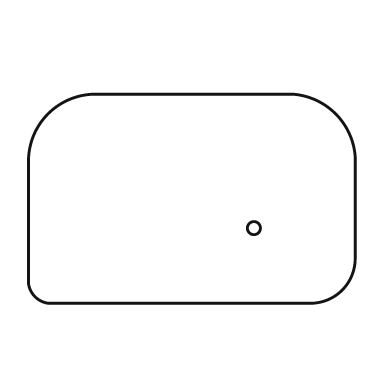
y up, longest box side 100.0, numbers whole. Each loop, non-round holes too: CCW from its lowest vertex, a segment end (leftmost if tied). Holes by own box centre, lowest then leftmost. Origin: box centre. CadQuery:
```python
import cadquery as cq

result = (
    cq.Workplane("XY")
    .moveTo(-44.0, -32.0)
    .lineTo(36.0, -32.0)
    .threePointArc((46.0, -28.0), (50.0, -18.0))
    .lineTo(50.0, 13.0)
    .threePointArc((44.0, 26.0), (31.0, 32.0))
    .lineTo(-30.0, 32.0)
    .threePointArc((-44.0, 26.0), (-50.0, 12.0))
    .lineTo(-50.0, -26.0)
    .threePointArc((-48.0, -30.0), (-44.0, -32.0))
    .close()
    .moveTo(19.0, -9.0)
    .circle(2.0)
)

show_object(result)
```